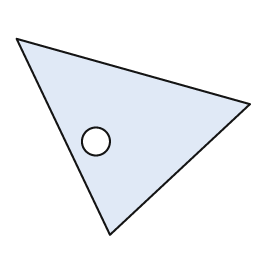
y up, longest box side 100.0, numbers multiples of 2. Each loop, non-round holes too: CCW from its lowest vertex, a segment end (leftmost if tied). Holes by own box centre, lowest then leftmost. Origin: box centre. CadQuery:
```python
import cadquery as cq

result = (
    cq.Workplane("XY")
    .moveTo(-10.0, -42.0)
    .lineTo(50.0, 14.0)
    .lineTo(-50.0, 42.0)
    .close()
    .moveTo(-16.0, -2.0)
    .circle(6.0)
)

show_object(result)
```